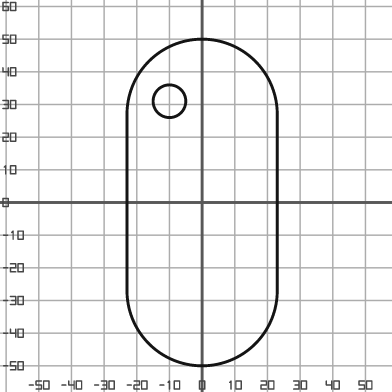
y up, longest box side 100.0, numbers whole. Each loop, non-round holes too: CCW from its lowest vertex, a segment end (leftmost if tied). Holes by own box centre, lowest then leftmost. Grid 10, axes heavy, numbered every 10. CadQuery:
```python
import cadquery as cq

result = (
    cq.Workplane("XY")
    .moveTo(-23.0, -27.0)
    .threePointArc((0.0, -50.0), (23.0, -27.0))
    .lineTo(23.0, 27.0)
    .threePointArc((0.0, 50.0), (-23.0, 27.0))
    .close()
    .moveTo(-10.0, 31.0)
    .circle(5.0)
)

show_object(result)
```